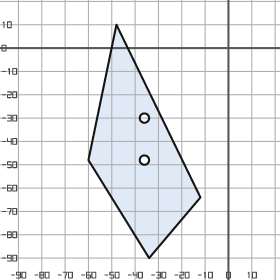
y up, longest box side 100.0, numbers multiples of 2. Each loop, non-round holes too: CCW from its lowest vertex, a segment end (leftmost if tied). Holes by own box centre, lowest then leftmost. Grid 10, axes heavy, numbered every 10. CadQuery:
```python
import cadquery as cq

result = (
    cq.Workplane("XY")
    .moveTo(-34.0, -90.0)
    .lineTo(-12.0, -64.0)
    .lineTo(-48.0, 10.0)
    .lineTo(-60.0, -48.0)
    .close()
    .moveTo(-36.0, -48.0)
    .circle(2.0)
    .moveTo(-36.0, -30.0)
    .circle(2.0)
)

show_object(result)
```